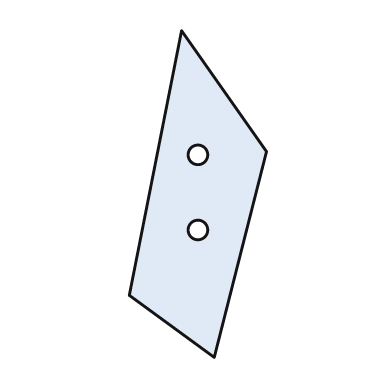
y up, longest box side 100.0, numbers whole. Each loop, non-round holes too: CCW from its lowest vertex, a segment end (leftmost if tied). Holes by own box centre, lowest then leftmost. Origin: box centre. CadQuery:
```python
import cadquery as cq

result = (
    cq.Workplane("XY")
    .moveTo(5.0, -50.0)
    .lineTo(21.0, 13.0)
    .lineTo(-5.0, 50.0)
    .lineTo(-21.0, -31.0)
    .close()
    .moveTo(0.0, -11.0)
    .circle(3.0)
    .moveTo(0.0, 12.0)
    .circle(3.0)
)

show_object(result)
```